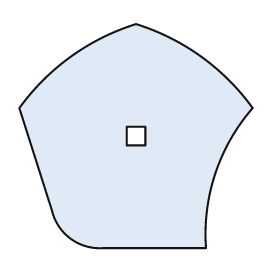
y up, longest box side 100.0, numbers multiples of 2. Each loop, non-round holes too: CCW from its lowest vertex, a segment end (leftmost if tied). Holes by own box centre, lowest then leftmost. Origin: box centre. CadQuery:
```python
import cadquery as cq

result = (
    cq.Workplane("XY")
    .moveTo(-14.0, -48.0)
    .lineTo(30.0, -48.0)
    .threePointArc((34.0, -16.0), (50.0, 12.0))
    .threePointArc((28.0, 34.0), (0.0, 48.0))
    .threePointArc((-28.0, 34.0), (-50.0, 12.0))
    .lineTo(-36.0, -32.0)
    .threePointArc((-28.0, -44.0), (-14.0, -48.0))
    .close()
    .moveTo(-4.0, -4.0)
    .lineTo(4.0, -4.0)
    .lineTo(4.0, 4.0)
    .lineTo(-4.0, 4.0)
    .close()
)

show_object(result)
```